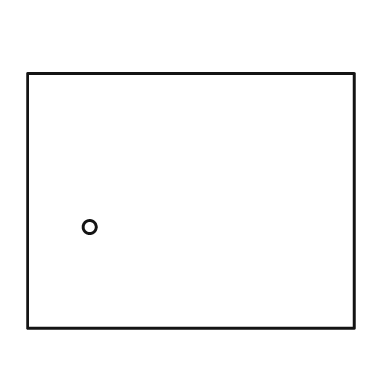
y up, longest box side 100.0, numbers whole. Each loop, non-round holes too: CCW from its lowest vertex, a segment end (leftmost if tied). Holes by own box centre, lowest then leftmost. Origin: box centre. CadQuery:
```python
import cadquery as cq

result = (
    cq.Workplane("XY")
    .moveTo(-50.0, -39.0)
    .lineTo(50.0, -39.0)
    .lineTo(50.0, 39.0)
    .lineTo(-50.0, 39.0)
    .close()
    .moveTo(-31.0, -8.0)
    .circle(2.0)
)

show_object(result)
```